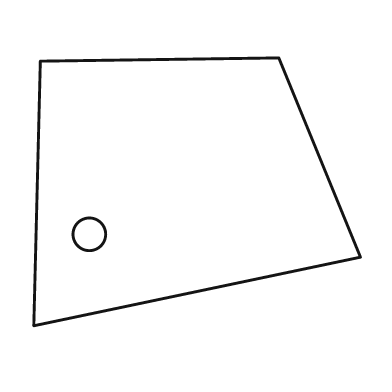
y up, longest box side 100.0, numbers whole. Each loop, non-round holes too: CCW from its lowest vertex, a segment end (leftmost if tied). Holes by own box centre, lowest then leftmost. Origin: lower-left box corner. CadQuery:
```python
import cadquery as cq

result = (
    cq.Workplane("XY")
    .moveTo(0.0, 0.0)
    .lineTo(100.0, 21.0)
    .lineTo(75.0, 82.0)
    .lineTo(2.0, 81.0)
    .close()
    .moveTo(17.0, 28.0)
    .circle(5.0)
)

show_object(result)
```